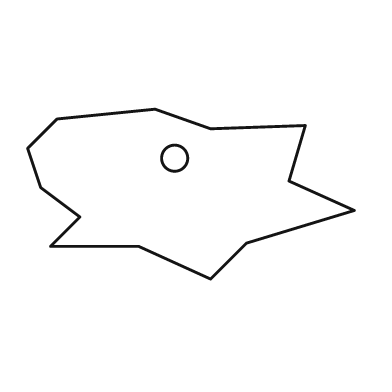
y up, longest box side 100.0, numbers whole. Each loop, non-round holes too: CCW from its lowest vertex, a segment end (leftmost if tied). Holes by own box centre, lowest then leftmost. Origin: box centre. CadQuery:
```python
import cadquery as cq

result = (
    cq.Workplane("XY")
    .moveTo(6.0, -26.0)
    .lineTo(17.0, -15.0)
    .lineTo(50.0, -5.0)
    .lineTo(30.0, 4.0)
    .lineTo(35.0, 21.0)
    .lineTo(6.0, 20.0)
    .lineTo(-11.0, 26.0)
    .lineTo(-41.0, 23.0)
    .lineTo(-50.0, 14.0)
    .lineTo(-46.0, 2.0)
    .lineTo(-34.0, -7.0)
    .lineTo(-43.0, -16.0)
    .lineTo(-16.0, -16.0)
    .close()
    .moveTo(-5.0, 11.0)
    .circle(4.0)
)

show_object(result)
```